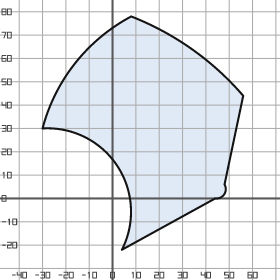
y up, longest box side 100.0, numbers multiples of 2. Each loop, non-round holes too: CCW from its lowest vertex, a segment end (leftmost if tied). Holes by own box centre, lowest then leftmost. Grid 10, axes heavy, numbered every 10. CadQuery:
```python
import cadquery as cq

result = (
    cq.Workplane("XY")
    .moveTo(4.0, -22.0)
    .lineTo(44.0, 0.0)
    .threePointArc((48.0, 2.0), (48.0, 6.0))
    .lineTo(56.0, 44.0)
    .threePointArc((34.0, 64.0), (8.0, 78.0))
    .threePointArc((-16.0, 58.0), (-30.0, 30.0))
    .threePointArc((2.0, 14.0), (4.0, -22.0))
    .close()
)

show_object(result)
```